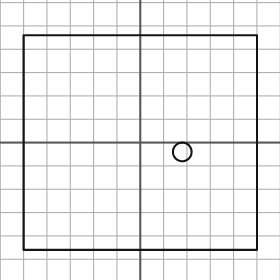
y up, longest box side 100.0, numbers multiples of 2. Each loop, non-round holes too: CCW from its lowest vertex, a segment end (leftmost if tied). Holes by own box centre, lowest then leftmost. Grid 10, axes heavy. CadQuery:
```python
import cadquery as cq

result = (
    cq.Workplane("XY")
    .moveTo(-50.0, -46.0)
    .lineTo(50.0, -46.0)
    .lineTo(50.0, 46.0)
    .lineTo(-50.0, 46.0)
    .close()
    .moveTo(18.0, -4.0)
    .circle(4.0)
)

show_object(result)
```